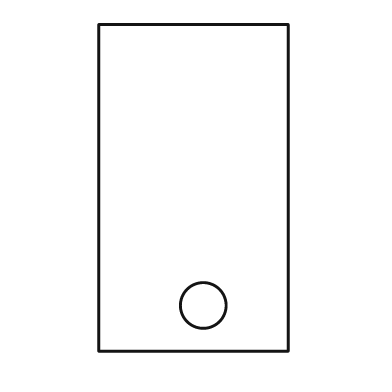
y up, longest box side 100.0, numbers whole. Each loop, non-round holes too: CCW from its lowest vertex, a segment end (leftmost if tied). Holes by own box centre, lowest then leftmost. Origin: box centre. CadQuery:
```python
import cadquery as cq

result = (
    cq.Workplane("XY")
    .moveTo(-29.0, -50.0)
    .lineTo(29.0, -50.0)
    .lineTo(29.0, 50.0)
    .lineTo(-29.0, 50.0)
    .close()
    .moveTo(3.0, -36.0)
    .circle(7.0)
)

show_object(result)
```